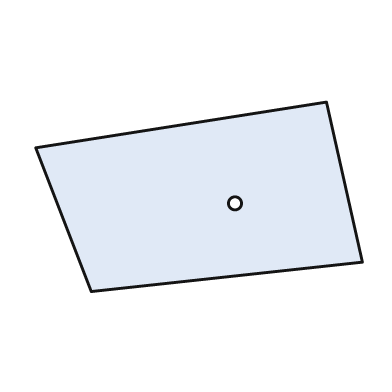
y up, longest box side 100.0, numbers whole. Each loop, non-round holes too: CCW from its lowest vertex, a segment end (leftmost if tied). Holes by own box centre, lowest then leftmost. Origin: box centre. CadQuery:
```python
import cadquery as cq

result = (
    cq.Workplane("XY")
    .moveTo(-33.0, -29.0)
    .lineTo(50.0, -20.0)
    .lineTo(39.0, 29.0)
    .lineTo(-50.0, 15.0)
    .close()
    .moveTo(11.0, -2.0)
    .circle(2.0)
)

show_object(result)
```